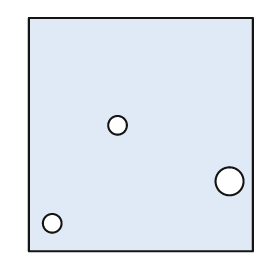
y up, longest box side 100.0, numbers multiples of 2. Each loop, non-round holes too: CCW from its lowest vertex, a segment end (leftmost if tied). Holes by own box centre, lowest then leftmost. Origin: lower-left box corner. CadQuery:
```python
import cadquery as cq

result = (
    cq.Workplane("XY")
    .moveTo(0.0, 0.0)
    .lineTo(96.0, 0.0)
    .lineTo(96.0, 100.0)
    .lineTo(0.0, 100.0)
    .close()
    .moveTo(10.0, 12.0)
    .circle(4.0)
    .moveTo(86.0, 30.0)
    .circle(6.0)
    .moveTo(38.0, 54.0)
    .circle(4.0)
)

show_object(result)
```